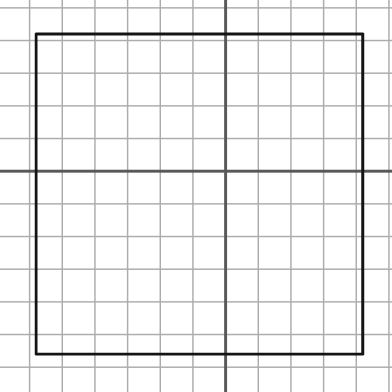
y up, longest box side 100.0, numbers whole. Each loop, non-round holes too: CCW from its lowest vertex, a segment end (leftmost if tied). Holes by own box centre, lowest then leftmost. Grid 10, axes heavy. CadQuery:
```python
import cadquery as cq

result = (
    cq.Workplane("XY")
    .moveTo(-58.0, -56.0)
    .lineTo(42.0, -56.0)
    .lineTo(42.0, 42.0)
    .lineTo(-58.0, 42.0)
    .close()
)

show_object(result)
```